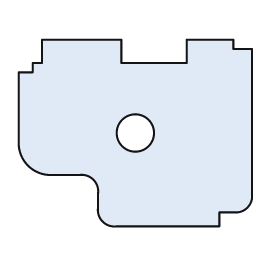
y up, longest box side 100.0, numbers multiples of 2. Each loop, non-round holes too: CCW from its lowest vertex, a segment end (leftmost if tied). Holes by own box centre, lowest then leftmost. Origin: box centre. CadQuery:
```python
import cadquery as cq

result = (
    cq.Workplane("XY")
    .moveTo(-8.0, -40.0)
    .lineTo(36.0, -40.0)
    .lineTo(36.0, -34.0)
    .lineTo(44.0, -34.0)
    .threePointArc((48.0, -32.0), (50.0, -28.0))
    .lineTo(50.0, 36.0)
    .lineTo(42.0, 36.0)
    .lineTo(42.0, 40.0)
    .lineTo(22.0, 40.0)
    .lineTo(22.0, 30.0)
    .lineTo(-6.0, 30.0)
    .lineTo(-6.0, 40.0)
    .lineTo(-40.0, 40.0)
    .lineTo(-40.0, 30.0)
    .lineTo(-44.0, 30.0)
    .lineTo(-44.0, 26.0)
    .lineTo(-50.0, 26.0)
    .lineTo(-50.0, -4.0)
    .threePointArc((-46.0, -14.0), (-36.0, -18.0))
    .lineTo(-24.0, -18.0)
    .threePointArc((-18.0, -20.0), (-16.0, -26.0))
    .lineTo(-16.0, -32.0)
    .threePointArc((-14.0, -38.0), (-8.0, -40.0))
    .close()
    .moveTo(0.0, 0.0)
    .circle(8.0)
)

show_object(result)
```